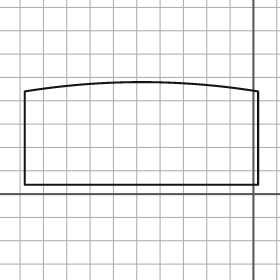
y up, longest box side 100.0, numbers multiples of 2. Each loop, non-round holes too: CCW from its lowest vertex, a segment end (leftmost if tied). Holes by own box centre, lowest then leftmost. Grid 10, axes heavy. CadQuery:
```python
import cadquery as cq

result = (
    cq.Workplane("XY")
    .moveTo(-98.0, 4.0)
    .lineTo(2.0, 4.0)
    .lineTo(2.0, 44.0)
    .threePointArc((-48.0, 48.0), (-98.0, 44.0))
    .close()
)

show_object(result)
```